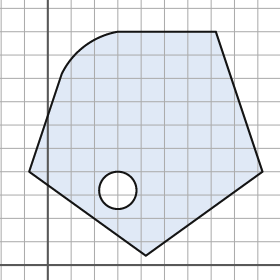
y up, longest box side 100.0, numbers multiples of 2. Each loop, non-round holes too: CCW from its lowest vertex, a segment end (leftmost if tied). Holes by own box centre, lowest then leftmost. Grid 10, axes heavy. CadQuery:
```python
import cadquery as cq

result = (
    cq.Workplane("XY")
    .moveTo(42.0, 4.0)
    .lineTo(92.0, 40.0)
    .lineTo(72.0, 100.0)
    .lineTo(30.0, 100.0)
    .threePointArc((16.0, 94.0), (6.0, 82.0))
    .lineTo(-8.0, 40.0)
    .close()
    .moveTo(30.0, 32.0)
    .circle(8.0)
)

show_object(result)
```